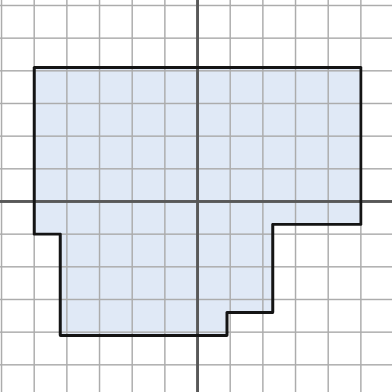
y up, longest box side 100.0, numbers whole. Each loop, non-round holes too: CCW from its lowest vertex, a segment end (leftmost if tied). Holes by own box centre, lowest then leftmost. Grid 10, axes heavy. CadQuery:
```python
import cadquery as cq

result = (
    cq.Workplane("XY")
    .moveTo(-42.0, -41.0)
    .lineTo(9.0, -41.0)
    .lineTo(9.0, -34.0)
    .lineTo(23.0, -34.0)
    .lineTo(23.0, -7.0)
    .lineTo(50.0, -7.0)
    .lineTo(50.0, 41.0)
    .lineTo(-50.0, 41.0)
    .lineTo(-50.0, -10.0)
    .lineTo(-42.0, -10.0)
    .close()
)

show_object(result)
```